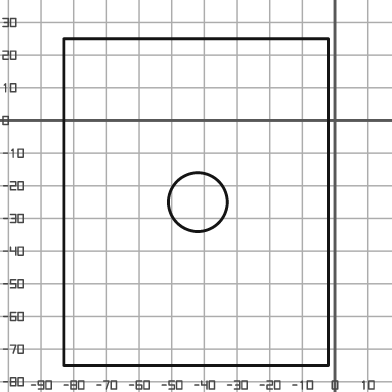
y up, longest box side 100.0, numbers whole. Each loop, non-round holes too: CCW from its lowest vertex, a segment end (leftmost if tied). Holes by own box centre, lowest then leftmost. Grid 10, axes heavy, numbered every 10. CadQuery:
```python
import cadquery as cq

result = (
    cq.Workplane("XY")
    .moveTo(-83.0, -75.0)
    .lineTo(-2.0, -75.0)
    .lineTo(-2.0, 25.0)
    .lineTo(-83.0, 25.0)
    .close()
    .moveTo(-42.0, -25.0)
    .circle(9.0)
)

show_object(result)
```